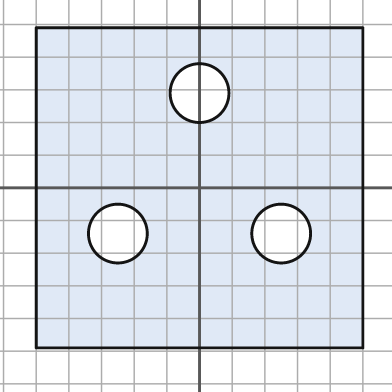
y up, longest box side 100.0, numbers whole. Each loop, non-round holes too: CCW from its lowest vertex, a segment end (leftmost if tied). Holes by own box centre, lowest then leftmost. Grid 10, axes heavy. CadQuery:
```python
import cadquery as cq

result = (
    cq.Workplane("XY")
    .moveTo(-50.0, -49.0)
    .lineTo(50.0, -49.0)
    .lineTo(50.0, 49.0)
    .lineTo(-50.0, 49.0)
    .close()
    .moveTo(-25.0, -14.0)
    .circle(9.0)
    .moveTo(25.0, -14.0)
    .circle(9.0)
    .moveTo(0.0, 29.0)
    .circle(9.0)
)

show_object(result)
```